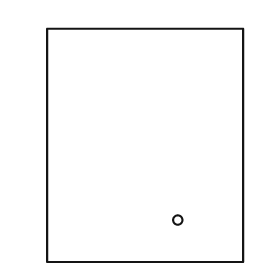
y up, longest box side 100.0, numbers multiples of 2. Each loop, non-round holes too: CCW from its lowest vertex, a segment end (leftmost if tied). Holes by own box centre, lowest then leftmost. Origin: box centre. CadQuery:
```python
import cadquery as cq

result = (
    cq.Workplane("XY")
    .moveTo(-42.0, -50.0)
    .lineTo(42.0, -50.0)
    .lineTo(42.0, 50.0)
    .lineTo(-42.0, 50.0)
    .close()
    .moveTo(14.0, -32.0)
    .circle(2.0)
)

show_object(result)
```